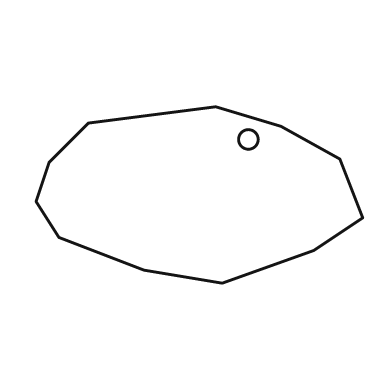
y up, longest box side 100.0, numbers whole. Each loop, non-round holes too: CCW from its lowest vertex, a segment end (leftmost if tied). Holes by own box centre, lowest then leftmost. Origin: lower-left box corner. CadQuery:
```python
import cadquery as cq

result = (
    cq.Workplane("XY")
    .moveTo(57.0, 0.0)
    .lineTo(85.0, 10.0)
    .lineTo(100.0, 20.0)
    .lineTo(93.0, 38.0)
    .lineTo(75.0, 48.0)
    .lineTo(55.0, 54.0)
    .lineTo(16.0, 49.0)
    .lineTo(4.0, 37.0)
    .lineTo(0.0, 25.0)
    .lineTo(7.0, 14.0)
    .lineTo(33.0, 4.0)
    .close()
    .moveTo(65.0, 44.0)
    .circle(3.0)
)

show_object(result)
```